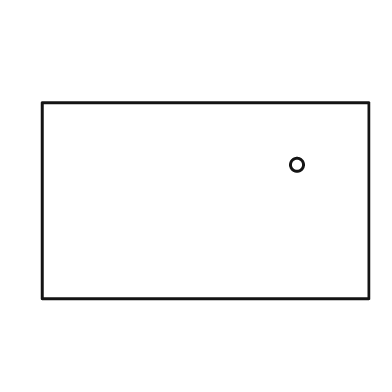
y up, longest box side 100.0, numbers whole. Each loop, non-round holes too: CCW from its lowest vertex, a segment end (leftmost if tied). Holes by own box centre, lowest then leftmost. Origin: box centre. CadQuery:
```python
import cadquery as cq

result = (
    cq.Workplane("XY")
    .moveTo(-50.0, -30.0)
    .lineTo(50.0, -30.0)
    .lineTo(50.0, 30.0)
    .lineTo(-50.0, 30.0)
    .close()
    .moveTo(28.0, 11.0)
    .circle(2.0)
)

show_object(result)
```